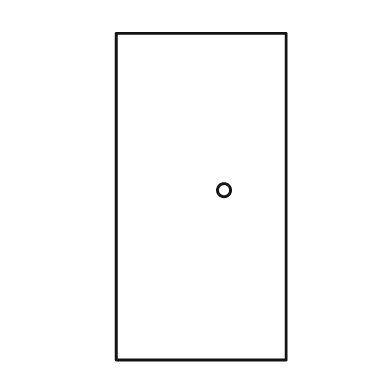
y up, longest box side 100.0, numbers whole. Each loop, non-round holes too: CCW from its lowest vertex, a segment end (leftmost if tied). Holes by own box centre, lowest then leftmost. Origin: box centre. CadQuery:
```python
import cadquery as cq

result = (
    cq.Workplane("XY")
    .moveTo(-26.0, -50.0)
    .lineTo(26.0, -50.0)
    .lineTo(26.0, 50.0)
    .lineTo(-26.0, 50.0)
    .close()
    .moveTo(7.0, 2.0)
    .circle(2.0)
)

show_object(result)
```